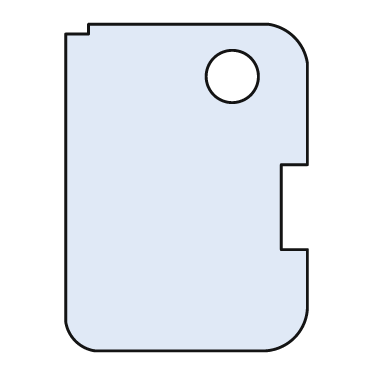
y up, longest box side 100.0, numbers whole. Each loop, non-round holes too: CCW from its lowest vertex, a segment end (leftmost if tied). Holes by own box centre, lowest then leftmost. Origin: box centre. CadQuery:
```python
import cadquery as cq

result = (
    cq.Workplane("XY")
    .moveTo(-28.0, -50.0)
    .lineTo(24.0, -50.0)
    .threePointArc((33.0, -46.0), (37.0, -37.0))
    .lineTo(37.0, -19.0)
    .lineTo(29.0, -19.0)
    .lineTo(29.0, 7.0)
    .lineTo(37.0, 7.0)
    .lineTo(37.0, 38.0)
    .threePointArc((33.0, 46.0), (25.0, 50.0))
    .lineTo(-30.0, 50.0)
    .lineTo(-30.0, 47.0)
    .lineTo(-37.0, 47.0)
    .lineTo(-37.0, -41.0)
    .threePointArc((-34.0, -47.0), (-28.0, -50.0))
    .close()
    .moveTo(14.0, 34.0)
    .circle(8.0)
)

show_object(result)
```